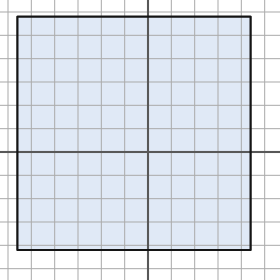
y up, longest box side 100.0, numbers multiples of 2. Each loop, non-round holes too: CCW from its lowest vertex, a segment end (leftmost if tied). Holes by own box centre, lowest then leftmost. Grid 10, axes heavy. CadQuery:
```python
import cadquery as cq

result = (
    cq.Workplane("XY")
    .moveTo(-56.0, -42.0)
    .lineTo(44.0, -42.0)
    .lineTo(44.0, 58.0)
    .lineTo(-56.0, 58.0)
    .close()
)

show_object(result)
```